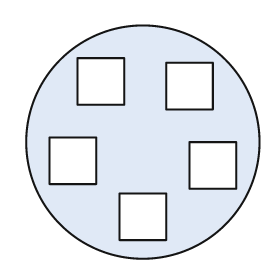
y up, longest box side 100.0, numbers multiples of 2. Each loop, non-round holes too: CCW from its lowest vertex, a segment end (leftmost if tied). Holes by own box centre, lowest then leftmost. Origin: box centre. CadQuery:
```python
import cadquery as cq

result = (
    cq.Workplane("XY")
    .moveTo(0.0, 0.0)
    .circle(50.0)
    .moveTo(-10.0, -42.0)
    .lineTo(10.0, -42.0)
    .lineTo(10.0, -22.0)
    .lineTo(-10.0, -22.0)
    .close()
    .moveTo(20.0, -20.0)
    .lineTo(40.0, -20.0)
    .lineTo(40.0, 0.0)
    .lineTo(20.0, 0.0)
    .close()
    .moveTo(-40.0, -18.0)
    .lineTo(-20.0, -18.0)
    .lineTo(-20.0, 2.0)
    .lineTo(-40.0, 2.0)
    .close()
    .moveTo(10.0, 14.0)
    .lineTo(30.0, 14.0)
    .lineTo(30.0, 34.0)
    .lineTo(10.0, 34.0)
    .close()
    .moveTo(-28.0, 16.0)
    .lineTo(-8.0, 16.0)
    .lineTo(-8.0, 36.0)
    .lineTo(-28.0, 36.0)
    .close()
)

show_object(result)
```